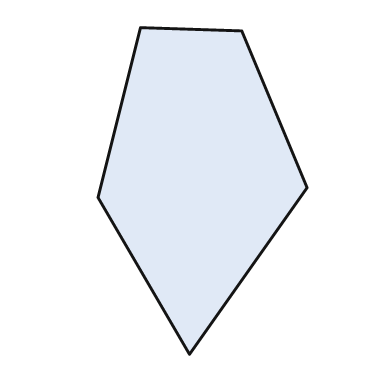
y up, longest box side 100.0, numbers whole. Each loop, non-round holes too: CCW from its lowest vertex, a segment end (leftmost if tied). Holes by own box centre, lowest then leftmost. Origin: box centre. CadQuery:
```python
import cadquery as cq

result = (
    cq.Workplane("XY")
    .moveTo(-4.0, -50.0)
    .lineTo(32.0, 1.0)
    .lineTo(12.0, 49.0)
    .lineTo(-19.0, 50.0)
    .lineTo(-32.0, -2.0)
    .close()
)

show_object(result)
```